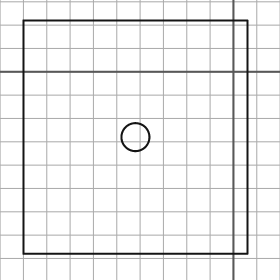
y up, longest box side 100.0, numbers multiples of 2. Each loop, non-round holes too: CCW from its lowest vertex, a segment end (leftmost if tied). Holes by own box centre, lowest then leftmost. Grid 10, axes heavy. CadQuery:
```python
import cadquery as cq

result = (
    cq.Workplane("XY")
    .moveTo(-90.0, -78.0)
    .lineTo(6.0, -78.0)
    .lineTo(6.0, 22.0)
    .lineTo(-90.0, 22.0)
    .close()
    .moveTo(-42.0, -28.0)
    .circle(6.0)
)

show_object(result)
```